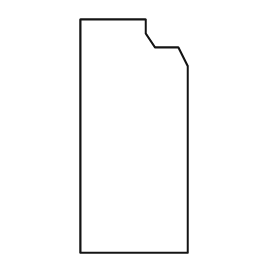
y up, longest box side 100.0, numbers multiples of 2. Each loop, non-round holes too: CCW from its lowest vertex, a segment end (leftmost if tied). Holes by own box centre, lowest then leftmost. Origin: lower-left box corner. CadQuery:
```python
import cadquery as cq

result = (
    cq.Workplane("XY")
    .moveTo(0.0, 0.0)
    .lineTo(46.0, 0.0)
    .lineTo(46.0, 80.0)
    .lineTo(42.0, 88.0)
    .lineTo(32.0, 88.0)
    .lineTo(28.0, 94.0)
    .lineTo(28.0, 100.0)
    .lineTo(0.0, 100.0)
    .close()
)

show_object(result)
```